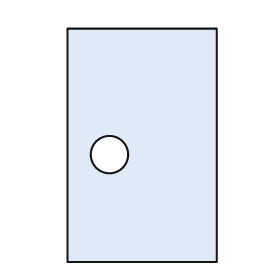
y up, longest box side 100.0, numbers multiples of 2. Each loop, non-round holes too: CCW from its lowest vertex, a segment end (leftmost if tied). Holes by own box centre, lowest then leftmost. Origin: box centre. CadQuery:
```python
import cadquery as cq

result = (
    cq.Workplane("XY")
    .moveTo(-32.0, -50.0)
    .lineTo(32.0, -50.0)
    .lineTo(32.0, 50.0)
    .lineTo(-32.0, 50.0)
    .close()
    .moveTo(-14.0, -4.0)
    .circle(8.0)
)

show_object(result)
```